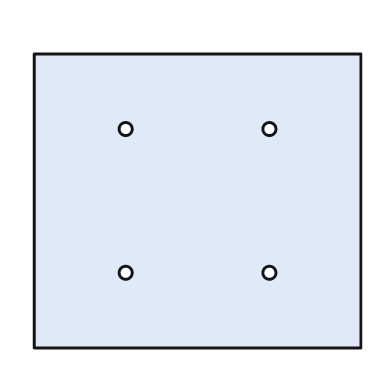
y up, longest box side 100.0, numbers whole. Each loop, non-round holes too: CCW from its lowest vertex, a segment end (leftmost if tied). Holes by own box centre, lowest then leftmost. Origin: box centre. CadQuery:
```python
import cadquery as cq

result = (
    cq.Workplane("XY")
    .moveTo(-50.0, -45.0)
    .lineTo(50.0, -45.0)
    .lineTo(50.0, 45.0)
    .lineTo(-50.0, 45.0)
    .close()
    .moveTo(-22.0, -22.0)
    .circle(2.0)
    .moveTo(22.0, -22.0)
    .circle(2.0)
    .moveTo(-22.0, 22.0)
    .circle(2.0)
    .moveTo(22.0, 22.0)
    .circle(2.0)
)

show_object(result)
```